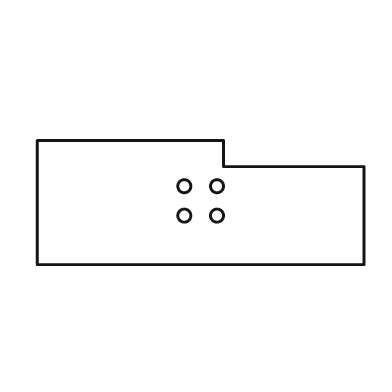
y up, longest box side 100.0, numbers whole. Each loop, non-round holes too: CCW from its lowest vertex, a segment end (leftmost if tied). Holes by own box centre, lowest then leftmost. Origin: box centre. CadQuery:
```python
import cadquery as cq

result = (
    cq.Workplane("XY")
    .moveTo(-50.0, -19.0)
    .lineTo(50.0, -19.0)
    .lineTo(50.0, 11.0)
    .lineTo(7.0, 11.0)
    .lineTo(7.0, 19.0)
    .lineTo(-50.0, 19.0)
    .close()
    .moveTo(-5.0, -4.0)
    .circle(2.0)
    .moveTo(5.0, -4.0)
    .circle(2.0)
    .moveTo(-5.0, 5.0)
    .circle(2.0)
    .moveTo(5.0, 5.0)
    .circle(2.0)
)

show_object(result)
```